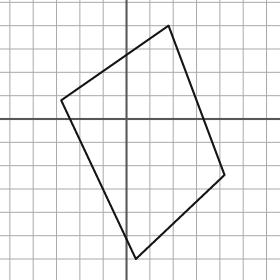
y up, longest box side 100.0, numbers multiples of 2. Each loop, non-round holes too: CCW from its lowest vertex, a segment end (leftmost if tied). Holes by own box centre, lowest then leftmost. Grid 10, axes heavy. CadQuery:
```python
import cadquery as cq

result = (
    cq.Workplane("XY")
    .moveTo(4.0, -60.0)
    .lineTo(42.0, -24.0)
    .lineTo(18.0, 40.0)
    .lineTo(-28.0, 8.0)
    .close()
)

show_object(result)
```